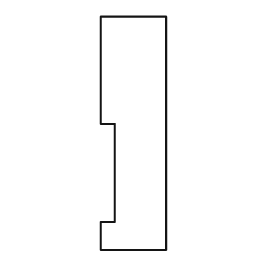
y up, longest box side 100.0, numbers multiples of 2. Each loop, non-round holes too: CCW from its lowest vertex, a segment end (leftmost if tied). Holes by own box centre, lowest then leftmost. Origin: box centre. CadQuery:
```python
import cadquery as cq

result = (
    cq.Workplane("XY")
    .moveTo(-14.0, -50.0)
    .lineTo(14.0, -50.0)
    .lineTo(14.0, 50.0)
    .lineTo(-14.0, 50.0)
    .lineTo(-14.0, 4.0)
    .lineTo(-8.0, 4.0)
    .lineTo(-8.0, -38.0)
    .lineTo(-14.0, -38.0)
    .close()
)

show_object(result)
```